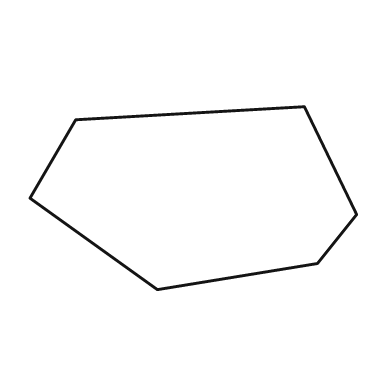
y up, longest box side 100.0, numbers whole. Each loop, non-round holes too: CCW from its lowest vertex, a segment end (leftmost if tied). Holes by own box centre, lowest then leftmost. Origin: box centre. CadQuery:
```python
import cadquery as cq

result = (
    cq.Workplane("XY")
    .moveTo(-11.0, -28.0)
    .lineTo(38.0, -20.0)
    .lineTo(50.0, -5.0)
    .lineTo(34.0, 28.0)
    .lineTo(-36.0, 24.0)
    .lineTo(-50.0, 0.0)
    .close()
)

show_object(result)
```